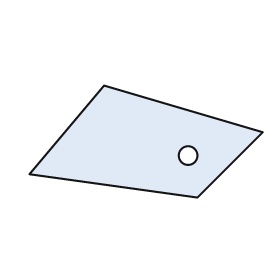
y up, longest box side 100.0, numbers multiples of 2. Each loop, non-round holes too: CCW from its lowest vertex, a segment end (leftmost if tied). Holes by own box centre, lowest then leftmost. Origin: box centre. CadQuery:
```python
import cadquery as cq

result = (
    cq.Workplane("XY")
    .moveTo(22.0, -24.0)
    .lineTo(50.0, 4.0)
    .lineTo(-18.0, 24.0)
    .lineTo(-50.0, -14.0)
    .close()
    .moveTo(18.0, -6.0)
    .circle(4.0)
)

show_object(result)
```